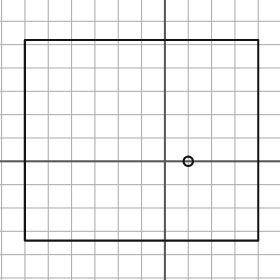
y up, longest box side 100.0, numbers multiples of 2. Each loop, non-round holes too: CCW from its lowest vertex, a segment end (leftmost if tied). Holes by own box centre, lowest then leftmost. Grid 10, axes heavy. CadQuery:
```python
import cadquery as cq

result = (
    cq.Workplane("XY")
    .moveTo(-60.0, -34.0)
    .lineTo(40.0, -34.0)
    .lineTo(40.0, 52.0)
    .lineTo(-60.0, 52.0)
    .close()
    .moveTo(10.0, 0.0)
    .circle(2.0)
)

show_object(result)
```